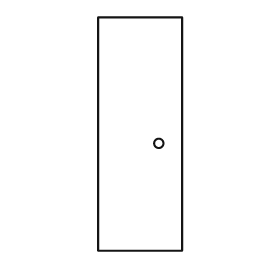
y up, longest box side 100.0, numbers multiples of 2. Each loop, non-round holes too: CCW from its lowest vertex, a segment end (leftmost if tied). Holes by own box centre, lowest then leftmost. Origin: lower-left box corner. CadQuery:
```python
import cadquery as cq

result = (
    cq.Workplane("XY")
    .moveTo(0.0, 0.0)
    .lineTo(36.0, 0.0)
    .lineTo(36.0, 100.0)
    .lineTo(0.0, 100.0)
    .close()
    .moveTo(26.0, 46.0)
    .circle(2.0)
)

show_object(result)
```